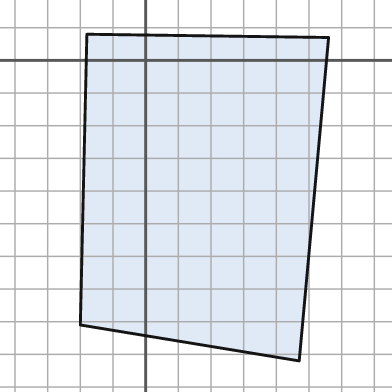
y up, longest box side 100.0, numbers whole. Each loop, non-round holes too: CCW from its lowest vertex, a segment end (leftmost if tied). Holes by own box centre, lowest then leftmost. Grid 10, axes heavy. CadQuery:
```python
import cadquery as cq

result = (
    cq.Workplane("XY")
    .moveTo(47.0, -92.0)
    .lineTo(56.0, 7.0)
    .lineTo(-18.0, 8.0)
    .lineTo(-20.0, -81.0)
    .close()
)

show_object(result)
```